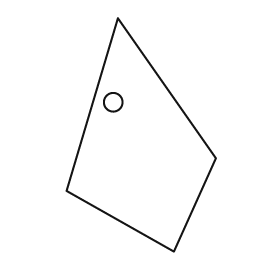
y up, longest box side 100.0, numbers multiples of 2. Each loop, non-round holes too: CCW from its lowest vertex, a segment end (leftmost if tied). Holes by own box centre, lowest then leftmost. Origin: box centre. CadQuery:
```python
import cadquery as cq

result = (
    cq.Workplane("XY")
    .moveTo(14.0, -50.0)
    .lineTo(32.0, -10.0)
    .lineTo(-10.0, 50.0)
    .lineTo(-32.0, -24.0)
    .close()
    .moveTo(-12.0, 14.0)
    .circle(4.0)
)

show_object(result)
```